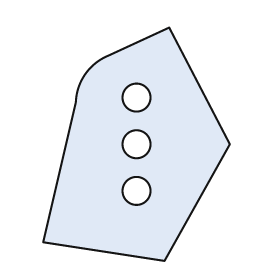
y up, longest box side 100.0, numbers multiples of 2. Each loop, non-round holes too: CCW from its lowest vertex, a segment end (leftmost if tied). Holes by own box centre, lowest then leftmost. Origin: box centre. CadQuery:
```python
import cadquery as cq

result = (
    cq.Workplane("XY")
    .moveTo(12.0, -50.0)
    .lineTo(40.0, 0.0)
    .lineTo(14.0, 50.0)
    .lineTo(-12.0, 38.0)
    .threePointArc((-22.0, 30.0), (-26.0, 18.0))
    .lineTo(-40.0, -42.0)
    .close()
    .moveTo(0.0, -20.0)
    .circle(6.0)
    .moveTo(0.0, 0.0)
    .circle(6.0)
    .moveTo(0.0, 20.0)
    .circle(6.0)
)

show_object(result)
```